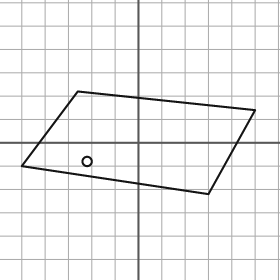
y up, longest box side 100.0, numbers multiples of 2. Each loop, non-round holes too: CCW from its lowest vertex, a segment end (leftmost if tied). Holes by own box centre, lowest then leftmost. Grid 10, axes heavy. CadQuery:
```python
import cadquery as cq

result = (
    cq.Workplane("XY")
    .moveTo(30.0, -22.0)
    .lineTo(50.0, 14.0)
    .lineTo(-26.0, 22.0)
    .lineTo(-50.0, -10.0)
    .close()
    .moveTo(-22.0, -8.0)
    .circle(2.0)
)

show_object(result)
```